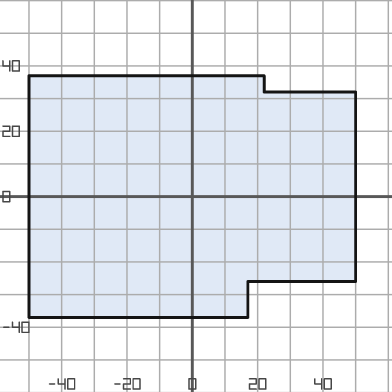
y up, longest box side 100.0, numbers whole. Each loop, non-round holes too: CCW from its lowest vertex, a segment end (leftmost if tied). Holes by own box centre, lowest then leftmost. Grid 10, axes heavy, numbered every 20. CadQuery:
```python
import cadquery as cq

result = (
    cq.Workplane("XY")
    .moveTo(-50.0, -37.0)
    .lineTo(17.0, -37.0)
    .lineTo(17.0, -26.0)
    .lineTo(50.0, -26.0)
    .lineTo(50.0, 32.0)
    .lineTo(22.0, 32.0)
    .lineTo(22.0, 37.0)
    .lineTo(-50.0, 37.0)
    .close()
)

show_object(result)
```